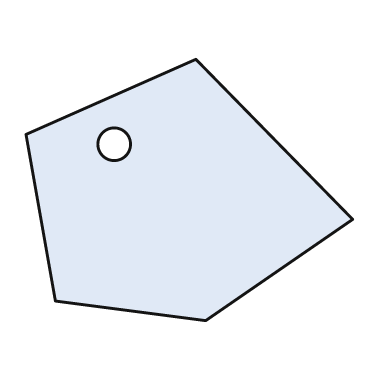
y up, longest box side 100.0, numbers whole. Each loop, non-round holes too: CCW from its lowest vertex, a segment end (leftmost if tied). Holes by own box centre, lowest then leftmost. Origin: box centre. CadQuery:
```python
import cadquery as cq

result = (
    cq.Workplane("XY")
    .moveTo(5.0, -40.0)
    .lineTo(50.0, -9.0)
    .lineTo(2.0, 40.0)
    .lineTo(-50.0, 17.0)
    .lineTo(-41.0, -34.0)
    .close()
    .moveTo(-23.0, 14.0)
    .circle(5.0)
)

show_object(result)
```